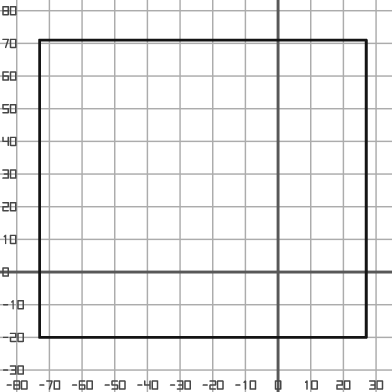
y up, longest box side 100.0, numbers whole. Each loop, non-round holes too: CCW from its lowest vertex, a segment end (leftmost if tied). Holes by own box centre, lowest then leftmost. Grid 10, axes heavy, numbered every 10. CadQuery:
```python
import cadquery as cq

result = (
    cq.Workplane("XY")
    .moveTo(-73.0, -20.0)
    .lineTo(27.0, -20.0)
    .lineTo(27.0, 71.0)
    .lineTo(-73.0, 71.0)
    .close()
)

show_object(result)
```